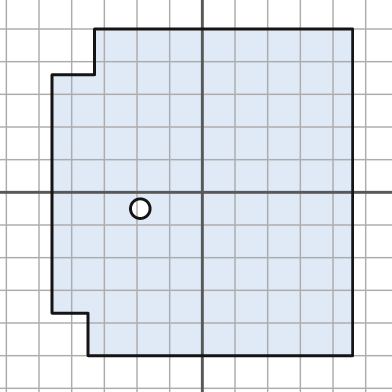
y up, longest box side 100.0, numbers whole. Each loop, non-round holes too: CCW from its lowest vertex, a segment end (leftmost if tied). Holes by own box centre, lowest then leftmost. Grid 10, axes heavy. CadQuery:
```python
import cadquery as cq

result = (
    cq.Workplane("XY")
    .moveTo(-35.0, -50.0)
    .lineTo(46.0, -50.0)
    .lineTo(46.0, 50.0)
    .lineTo(-33.0, 50.0)
    .lineTo(-33.0, 36.0)
    .lineTo(-46.0, 36.0)
    .lineTo(-46.0, -37.0)
    .lineTo(-35.0, -37.0)
    .close()
    .moveTo(-19.0, -5.0)
    .circle(3.0)
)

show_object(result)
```